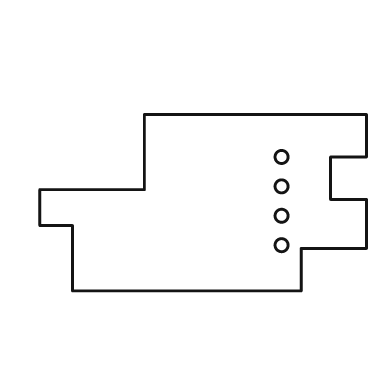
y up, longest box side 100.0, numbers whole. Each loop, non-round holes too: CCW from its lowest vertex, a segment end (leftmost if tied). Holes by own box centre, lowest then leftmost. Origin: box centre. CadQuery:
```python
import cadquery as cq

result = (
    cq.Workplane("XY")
    .moveTo(-40.0, -27.0)
    .lineTo(30.0, -27.0)
    .lineTo(30.0, -14.0)
    .lineTo(50.0, -14.0)
    .lineTo(50.0, 1.0)
    .lineTo(39.0, 1.0)
    .lineTo(39.0, 14.0)
    .lineTo(50.0, 14.0)
    .lineTo(50.0, 27.0)
    .lineTo(-18.0, 27.0)
    .lineTo(-18.0, 4.0)
    .lineTo(-50.0, 4.0)
    .lineTo(-50.0, -7.0)
    .lineTo(-40.0, -7.0)
    .close()
    .moveTo(24.0, -13.0)
    .circle(2.0)
    .moveTo(24.0, -4.0)
    .circle(2.0)
    .moveTo(24.0, 5.0)
    .circle(2.0)
    .moveTo(24.0, 14.0)
    .circle(2.0)
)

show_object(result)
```